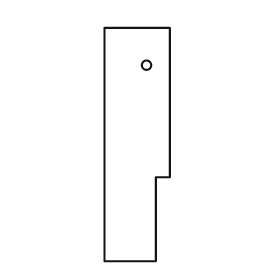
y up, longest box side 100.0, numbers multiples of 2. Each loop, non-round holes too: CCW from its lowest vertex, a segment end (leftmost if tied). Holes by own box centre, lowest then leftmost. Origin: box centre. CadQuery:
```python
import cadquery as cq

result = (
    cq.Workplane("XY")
    .moveTo(-14.0, -50.0)
    .lineTo(8.0, -50.0)
    .lineTo(8.0, -14.0)
    .lineTo(14.0, -14.0)
    .lineTo(14.0, 50.0)
    .lineTo(-14.0, 50.0)
    .close()
    .moveTo(4.0, 34.0)
    .circle(2.0)
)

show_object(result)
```